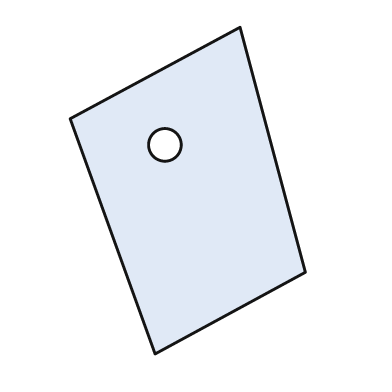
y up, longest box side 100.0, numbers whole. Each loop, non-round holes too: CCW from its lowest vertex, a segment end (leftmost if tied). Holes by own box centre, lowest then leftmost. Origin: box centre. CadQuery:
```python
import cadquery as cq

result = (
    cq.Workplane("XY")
    .moveTo(-10.0, -50.0)
    .lineTo(36.0, -25.0)
    .lineTo(16.0, 50.0)
    .lineTo(-36.0, 22.0)
    .close()
    .moveTo(-7.0, 14.0)
    .circle(5.0)
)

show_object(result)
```